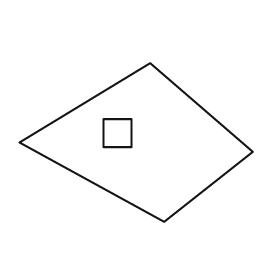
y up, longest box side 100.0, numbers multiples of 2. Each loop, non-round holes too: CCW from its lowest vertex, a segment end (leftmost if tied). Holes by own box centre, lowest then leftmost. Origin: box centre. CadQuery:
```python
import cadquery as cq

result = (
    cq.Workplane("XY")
    .moveTo(12.0, -34.0)
    .lineTo(50.0, -4.0)
    .lineTo(6.0, 34.0)
    .lineTo(-50.0, 0.0)
    .close()
    .moveTo(-14.0, -2.0)
    .lineTo(-2.0, -2.0)
    .lineTo(-2.0, 10.0)
    .lineTo(-14.0, 10.0)
    .close()
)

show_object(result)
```